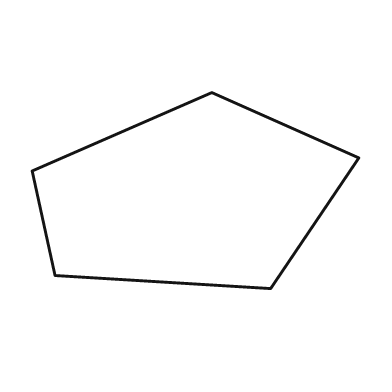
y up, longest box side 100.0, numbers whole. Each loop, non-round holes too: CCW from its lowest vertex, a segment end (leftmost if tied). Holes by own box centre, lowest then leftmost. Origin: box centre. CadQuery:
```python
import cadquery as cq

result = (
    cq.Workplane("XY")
    .moveTo(23.0, -30.0)
    .lineTo(50.0, 10.0)
    .lineTo(5.0, 30.0)
    .lineTo(-50.0, 6.0)
    .lineTo(-43.0, -26.0)
    .close()
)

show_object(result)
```